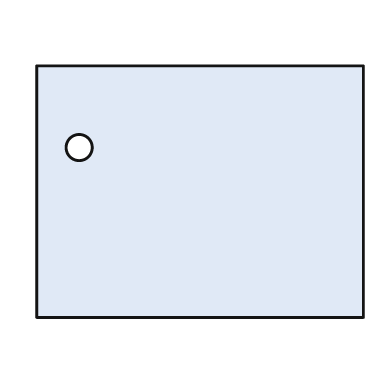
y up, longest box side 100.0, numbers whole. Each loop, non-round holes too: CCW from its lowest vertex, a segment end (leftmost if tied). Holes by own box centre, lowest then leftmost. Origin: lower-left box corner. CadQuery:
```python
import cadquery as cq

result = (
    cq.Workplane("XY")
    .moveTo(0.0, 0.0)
    .lineTo(100.0, 0.0)
    .lineTo(100.0, 77.0)
    .lineTo(0.0, 77.0)
    .close()
    .moveTo(13.0, 52.0)
    .circle(4.0)
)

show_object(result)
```